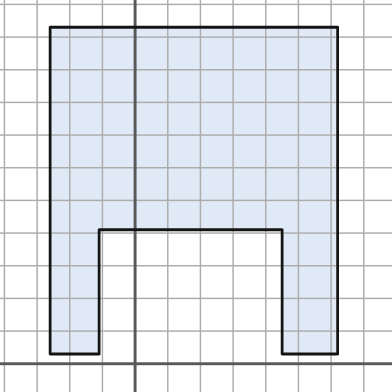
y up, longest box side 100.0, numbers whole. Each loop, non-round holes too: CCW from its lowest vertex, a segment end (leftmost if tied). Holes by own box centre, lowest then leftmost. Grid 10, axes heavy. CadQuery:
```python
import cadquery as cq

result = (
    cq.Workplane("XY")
    .moveTo(-26.0, 3.0)
    .lineTo(-11.0, 3.0)
    .lineTo(-11.0, 41.0)
    .lineTo(45.0, 41.0)
    .lineTo(45.0, 3.0)
    .lineTo(62.0, 3.0)
    .lineTo(62.0, 103.0)
    .lineTo(-26.0, 103.0)
    .close()
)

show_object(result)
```